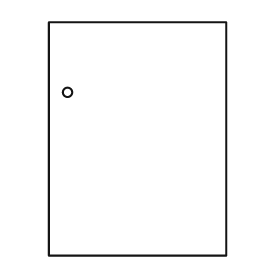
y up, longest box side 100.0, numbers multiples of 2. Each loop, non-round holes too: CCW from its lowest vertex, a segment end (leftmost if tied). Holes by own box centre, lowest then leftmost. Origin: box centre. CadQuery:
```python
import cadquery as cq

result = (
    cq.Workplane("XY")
    .moveTo(-38.0, -50.0)
    .lineTo(38.0, -50.0)
    .lineTo(38.0, 50.0)
    .lineTo(-38.0, 50.0)
    .close()
    .moveTo(-30.0, 20.0)
    .circle(2.0)
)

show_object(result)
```